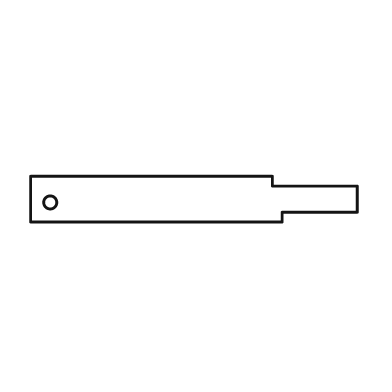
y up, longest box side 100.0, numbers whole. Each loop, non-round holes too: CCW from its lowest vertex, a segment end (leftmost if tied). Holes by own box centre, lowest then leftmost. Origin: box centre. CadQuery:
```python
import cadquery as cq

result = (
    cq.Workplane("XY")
    .moveTo(-50.0, -7.0)
    .lineTo(27.0, -7.0)
    .lineTo(27.0, -4.0)
    .lineTo(50.0, -4.0)
    .lineTo(50.0, 4.0)
    .lineTo(24.0, 4.0)
    .lineTo(24.0, 7.0)
    .lineTo(-50.0, 7.0)
    .close()
    .moveTo(-44.0, -1.0)
    .circle(2.0)
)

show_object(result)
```